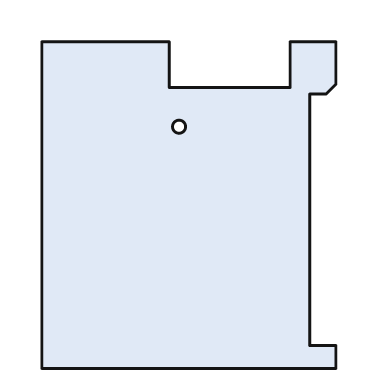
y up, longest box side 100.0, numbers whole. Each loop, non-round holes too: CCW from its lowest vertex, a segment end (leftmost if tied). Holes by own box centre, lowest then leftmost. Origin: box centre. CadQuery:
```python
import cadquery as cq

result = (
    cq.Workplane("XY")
    .moveTo(-45.0, -50.0)
    .lineTo(45.0, -50.0)
    .lineTo(45.0, -43.0)
    .lineTo(37.0, -43.0)
    .lineTo(37.0, 34.0)
    .lineTo(42.0, 34.0)
    .lineTo(45.0, 37.0)
    .lineTo(45.0, 50.0)
    .lineTo(31.0, 50.0)
    .lineTo(31.0, 36.0)
    .lineTo(-6.0, 36.0)
    .lineTo(-6.0, 50.0)
    .lineTo(-45.0, 50.0)
    .close()
    .moveTo(-3.0, 24.0)
    .circle(2.0)
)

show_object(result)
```